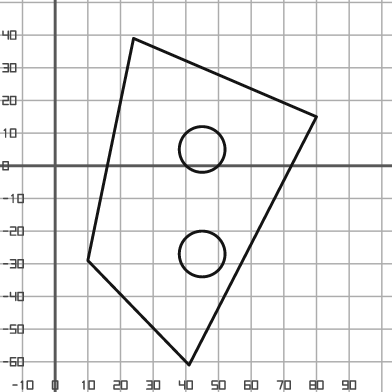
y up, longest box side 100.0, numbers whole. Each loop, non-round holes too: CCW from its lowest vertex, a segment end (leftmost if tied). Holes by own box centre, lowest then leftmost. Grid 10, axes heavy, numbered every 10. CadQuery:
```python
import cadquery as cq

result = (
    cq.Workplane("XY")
    .moveTo(41.0, -61.0)
    .lineTo(80.0, 15.0)
    .lineTo(24.0, 39.0)
    .lineTo(10.0, -29.0)
    .close()
    .moveTo(45.0, -27.0)
    .circle(7.0)
    .moveTo(45.0, 5.0)
    .circle(7.0)
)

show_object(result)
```